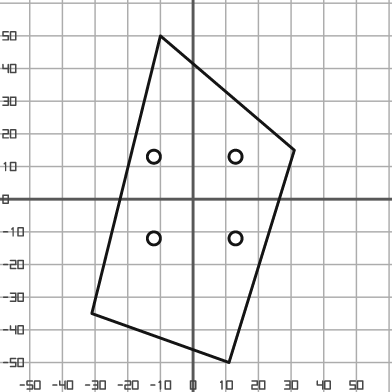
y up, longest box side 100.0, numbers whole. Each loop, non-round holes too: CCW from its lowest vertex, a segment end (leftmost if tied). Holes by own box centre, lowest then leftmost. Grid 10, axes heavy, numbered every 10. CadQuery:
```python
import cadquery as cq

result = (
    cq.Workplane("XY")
    .moveTo(11.0, -50.0)
    .lineTo(31.0, 15.0)
    .lineTo(-10.0, 50.0)
    .lineTo(-31.0, -35.0)
    .close()
    .moveTo(-12.0, -12.0)
    .circle(2.0)
    .moveTo(13.0, -12.0)
    .circle(2.0)
    .moveTo(-12.0, 13.0)
    .circle(2.0)
    .moveTo(13.0, 13.0)
    .circle(2.0)
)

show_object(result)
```